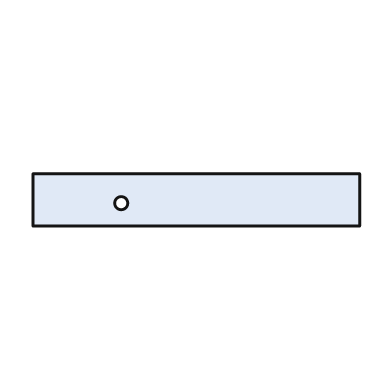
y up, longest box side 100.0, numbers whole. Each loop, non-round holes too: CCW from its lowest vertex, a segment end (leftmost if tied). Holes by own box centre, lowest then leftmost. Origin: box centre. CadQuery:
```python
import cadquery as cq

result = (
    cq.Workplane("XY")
    .moveTo(-50.0, -8.0)
    .lineTo(50.0, -8.0)
    .lineTo(50.0, 8.0)
    .lineTo(-50.0, 8.0)
    .close()
    .moveTo(-23.0, -1.0)
    .circle(2.0)
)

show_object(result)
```